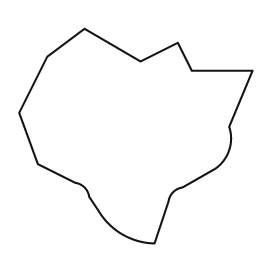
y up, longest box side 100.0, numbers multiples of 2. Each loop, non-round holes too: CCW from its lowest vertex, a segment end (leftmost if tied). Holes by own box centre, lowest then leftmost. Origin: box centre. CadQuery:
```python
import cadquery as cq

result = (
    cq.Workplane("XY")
    .moveTo(8.0, -46.0)
    .lineTo(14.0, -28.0)
    .threePointArc((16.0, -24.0), (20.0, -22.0))
    .lineTo(34.0, -14.0)
    .threePointArc((40.0, -6.0), (40.0, 4.0))
    .lineTo(50.0, 28.0)
    .lineTo(24.0, 28.0)
    .lineTo(18.0, 40.0)
    .lineTo(2.0, 32.0)
    .lineTo(-22.0, 46.0)
    .lineTo(-38.0, 34.0)
    .lineTo(-50.0, 10.0)
    .lineTo(-42.0, -12.0)
    .lineTo(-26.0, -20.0)
    .threePointArc((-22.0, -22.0), (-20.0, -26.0))
    .lineTo(-16.0, -32.0)
    .threePointArc((-6.0, -42.0), (8.0, -46.0))
    .close()
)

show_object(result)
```